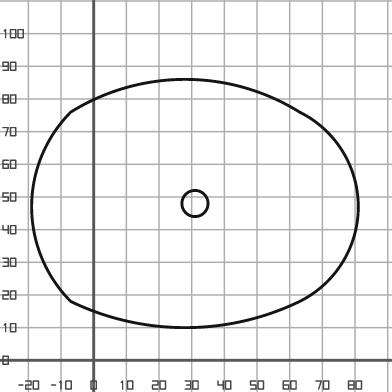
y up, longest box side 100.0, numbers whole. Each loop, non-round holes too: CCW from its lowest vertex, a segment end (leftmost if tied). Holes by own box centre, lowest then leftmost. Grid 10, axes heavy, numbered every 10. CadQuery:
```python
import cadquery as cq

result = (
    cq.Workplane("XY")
    .moveTo(-7.0, 18.0)
    .threePointArc((28.0, 10.0), (63.0, 18.0))
    .threePointArc((81.0, 47.0), (63.0, 76.0))
    .threePointArc((28.0, 86.0), (-7.0, 76.0))
    .threePointArc((-19.0, 47.0), (-7.0, 18.0))
    .close()
    .moveTo(31.0, 48.0)
    .circle(4.0)
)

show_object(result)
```